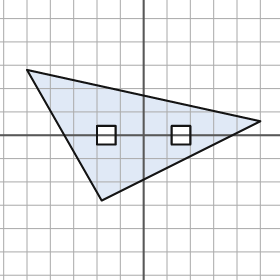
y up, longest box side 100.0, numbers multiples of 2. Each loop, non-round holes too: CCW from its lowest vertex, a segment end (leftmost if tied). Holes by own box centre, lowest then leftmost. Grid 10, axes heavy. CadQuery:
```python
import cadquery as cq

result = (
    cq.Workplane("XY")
    .moveTo(-18.0, -28.0)
    .lineTo(50.0, 6.0)
    .lineTo(-50.0, 28.0)
    .close()
    .moveTo(-20.0, -4.0)
    .lineTo(-12.0, -4.0)
    .lineTo(-12.0, 4.0)
    .lineTo(-20.0, 4.0)
    .close()
    .moveTo(12.0, -4.0)
    .lineTo(20.0, -4.0)
    .lineTo(20.0, 4.0)
    .lineTo(12.0, 4.0)
    .close()
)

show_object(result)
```